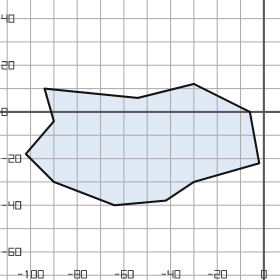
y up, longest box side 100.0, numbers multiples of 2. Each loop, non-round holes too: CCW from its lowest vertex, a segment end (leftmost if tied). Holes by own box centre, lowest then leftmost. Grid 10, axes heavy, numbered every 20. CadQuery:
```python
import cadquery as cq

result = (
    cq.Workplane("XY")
    .moveTo(-64.0, -40.0)
    .lineTo(-42.0, -38.0)
    .lineTo(-30.0, -30.0)
    .lineTo(-2.0, -22.0)
    .lineTo(-6.0, 0.0)
    .lineTo(-30.0, 12.0)
    .lineTo(-54.0, 6.0)
    .lineTo(-94.0, 10.0)
    .lineTo(-90.0, -4.0)
    .lineTo(-102.0, -18.0)
    .lineTo(-90.0, -30.0)
    .close()
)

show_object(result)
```